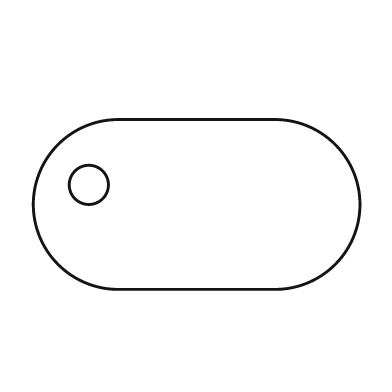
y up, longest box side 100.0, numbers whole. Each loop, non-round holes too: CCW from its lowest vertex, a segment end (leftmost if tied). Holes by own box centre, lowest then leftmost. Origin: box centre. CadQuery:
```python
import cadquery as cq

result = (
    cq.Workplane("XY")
    .moveTo(-24.0, -26.0)
    .lineTo(24.0, -26.0)
    .threePointArc((50.0, 0.0), (24.0, 26.0))
    .lineTo(-24.0, 26.0)
    .threePointArc((-50.0, 0.0), (-24.0, -26.0))
    .close()
    .moveTo(-33.0, 6.0)
    .circle(6.0)
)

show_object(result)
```